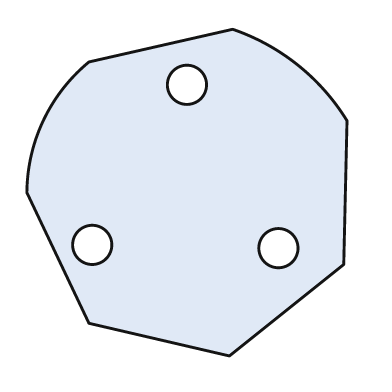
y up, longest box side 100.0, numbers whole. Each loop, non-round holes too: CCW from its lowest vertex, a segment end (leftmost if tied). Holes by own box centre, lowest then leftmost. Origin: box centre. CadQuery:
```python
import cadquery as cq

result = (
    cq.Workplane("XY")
    .moveTo(13.0, -50.0)
    .lineTo(48.0, -22.0)
    .lineTo(49.0, 22.0)
    .threePointArc((34.0, 39.0), (14.0, 50.0))
    .lineTo(-30.0, 40.0)
    .threePointArc((-44.0, 22.0), (-49.0, 0.0))
    .lineTo(-30.0, -40.0)
    .close()
    .moveTo(28.0, -17.0)
    .circle(6.0)
    .moveTo(-29.0, -16.0)
    .circle(6.0)
    .moveTo(0.0, 33.0)
    .circle(6.0)
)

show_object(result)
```